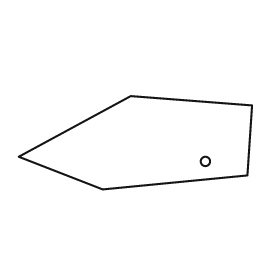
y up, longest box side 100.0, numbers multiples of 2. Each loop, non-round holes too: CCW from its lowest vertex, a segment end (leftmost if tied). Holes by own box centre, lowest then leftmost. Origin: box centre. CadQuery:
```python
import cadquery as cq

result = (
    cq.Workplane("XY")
    .moveTo(-14.0, -20.0)
    .lineTo(48.0, -14.0)
    .lineTo(50.0, 16.0)
    .lineTo(-2.0, 20.0)
    .lineTo(-50.0, -6.0)
    .close()
    .moveTo(30.0, -8.0)
    .circle(2.0)
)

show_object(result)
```